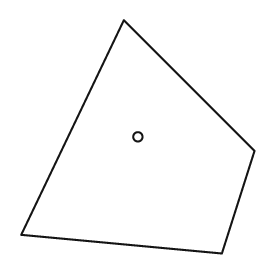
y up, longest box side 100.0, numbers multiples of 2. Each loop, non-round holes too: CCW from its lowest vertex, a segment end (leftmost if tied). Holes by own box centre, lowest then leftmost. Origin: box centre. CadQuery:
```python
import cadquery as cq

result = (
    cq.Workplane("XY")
    .moveTo(36.0, -50.0)
    .lineTo(50.0, -6.0)
    .lineTo(-6.0, 50.0)
    .lineTo(-50.0, -42.0)
    .close()
    .moveTo(0.0, 0.0)
    .circle(2.0)
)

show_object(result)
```